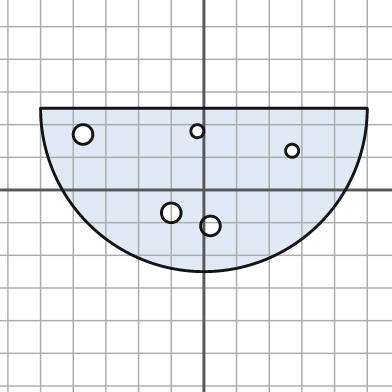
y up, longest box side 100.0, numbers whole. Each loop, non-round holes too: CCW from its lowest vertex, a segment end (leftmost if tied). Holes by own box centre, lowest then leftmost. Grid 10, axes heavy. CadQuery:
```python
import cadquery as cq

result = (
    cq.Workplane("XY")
    .moveTo(-50.0, 25.0)
    .threePointArc((0.0, -25.0), (50.0, 25.0))
    .close()
    .moveTo(2.0, -11.0)
    .circle(3.0)
    .moveTo(-10.0, -7.0)
    .circle(3.0)
    .moveTo(27.0, 12.0)
    .circle(2.0)
    .moveTo(-37.0, 17.0)
    .circle(3.0)
    .moveTo(-2.0, 18.0)
    .circle(2.0)
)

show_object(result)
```